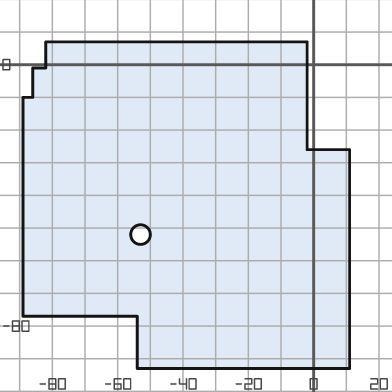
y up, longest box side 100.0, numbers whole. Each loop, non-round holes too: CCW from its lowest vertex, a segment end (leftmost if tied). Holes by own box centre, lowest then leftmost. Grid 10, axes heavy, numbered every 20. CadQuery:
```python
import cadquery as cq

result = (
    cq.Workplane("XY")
    .moveTo(-54.0, -93.0)
    .lineTo(11.0, -93.0)
    .lineTo(11.0, -26.0)
    .lineTo(-2.0, -26.0)
    .lineTo(-2.0, 7.0)
    .lineTo(-82.0, 7.0)
    .lineTo(-82.0, -1.0)
    .lineTo(-86.0, -1.0)
    .lineTo(-86.0, -10.0)
    .lineTo(-89.0, -10.0)
    .lineTo(-89.0, -77.0)
    .lineTo(-54.0, -77.0)
    .close()
    .moveTo(-53.0, -52.0)
    .circle(3.0)
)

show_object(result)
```